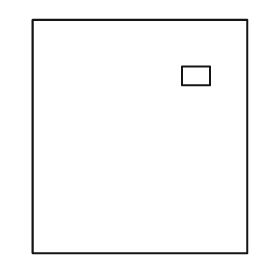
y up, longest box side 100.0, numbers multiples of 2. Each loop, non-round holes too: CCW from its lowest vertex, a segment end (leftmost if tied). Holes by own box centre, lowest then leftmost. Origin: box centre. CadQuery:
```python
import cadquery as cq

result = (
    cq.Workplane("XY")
    .moveTo(-46.0, -50.0)
    .lineTo(46.0, -50.0)
    .lineTo(46.0, 50.0)
    .lineTo(-46.0, 50.0)
    .close()
    .moveTo(18.0, 22.0)
    .lineTo(30.0, 22.0)
    .lineTo(30.0, 30.0)
    .lineTo(18.0, 30.0)
    .close()
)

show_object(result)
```